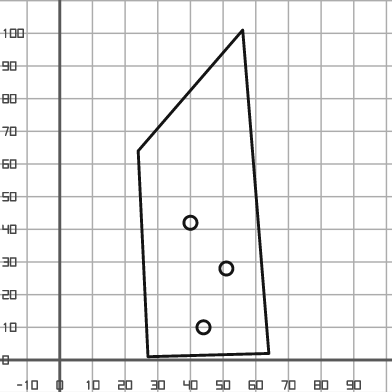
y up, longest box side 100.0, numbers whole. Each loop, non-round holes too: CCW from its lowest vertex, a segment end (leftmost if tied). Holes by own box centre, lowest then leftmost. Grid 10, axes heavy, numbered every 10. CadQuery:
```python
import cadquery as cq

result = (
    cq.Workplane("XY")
    .moveTo(27.0, 1.0)
    .lineTo(64.0, 2.0)
    .lineTo(56.0, 101.0)
    .lineTo(24.0, 64.0)
    .close()
    .moveTo(44.0, 10.0)
    .circle(2.0)
    .moveTo(51.0, 28.0)
    .circle(2.0)
    .moveTo(40.0, 42.0)
    .circle(2.0)
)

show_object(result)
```